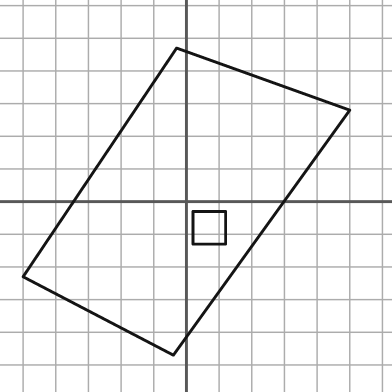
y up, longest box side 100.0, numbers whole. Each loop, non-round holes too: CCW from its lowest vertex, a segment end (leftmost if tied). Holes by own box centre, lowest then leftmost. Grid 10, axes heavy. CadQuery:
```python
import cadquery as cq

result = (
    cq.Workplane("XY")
    .moveTo(-4.0, -47.0)
    .lineTo(50.0, 28.0)
    .lineTo(-3.0, 47.0)
    .lineTo(-50.0, -23.0)
    .close()
    .moveTo(2.0, -13.0)
    .lineTo(12.0, -13.0)
    .lineTo(12.0, -3.0)
    .lineTo(2.0, -3.0)
    .close()
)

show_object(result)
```